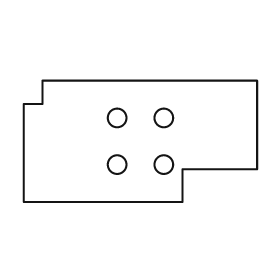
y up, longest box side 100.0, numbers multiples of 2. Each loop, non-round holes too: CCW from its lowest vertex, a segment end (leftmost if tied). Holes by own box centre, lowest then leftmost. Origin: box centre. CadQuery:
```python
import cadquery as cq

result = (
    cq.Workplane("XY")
    .moveTo(-50.0, -26.0)
    .lineTo(18.0, -26.0)
    .lineTo(18.0, -12.0)
    .lineTo(50.0, -12.0)
    .lineTo(50.0, 26.0)
    .lineTo(-42.0, 26.0)
    .lineTo(-42.0, 16.0)
    .lineTo(-50.0, 16.0)
    .close()
    .moveTo(-10.0, -10.0)
    .circle(4.0)
    .moveTo(10.0, -10.0)
    .circle(4.0)
    .moveTo(-10.0, 10.0)
    .circle(4.0)
    .moveTo(10.0, 10.0)
    .circle(4.0)
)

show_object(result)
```